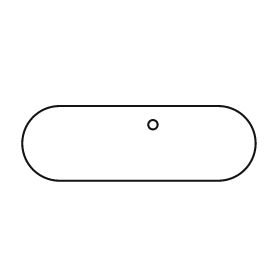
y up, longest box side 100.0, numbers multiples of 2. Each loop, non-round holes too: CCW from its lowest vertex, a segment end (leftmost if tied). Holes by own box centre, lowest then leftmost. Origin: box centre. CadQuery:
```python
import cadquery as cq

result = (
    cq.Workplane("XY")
    .moveTo(-34.0, -16.0)
    .lineTo(34.0, -16.0)
    .threePointArc((50.0, 0.0), (34.0, 16.0))
    .lineTo(-34.0, 16.0)
    .threePointArc((-50.0, 0.0), (-34.0, -16.0))
    .close()
    .moveTo(6.0, 8.0)
    .circle(2.0)
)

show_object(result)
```